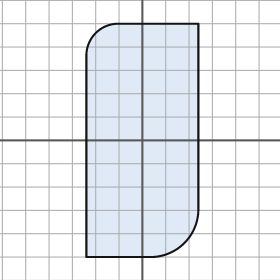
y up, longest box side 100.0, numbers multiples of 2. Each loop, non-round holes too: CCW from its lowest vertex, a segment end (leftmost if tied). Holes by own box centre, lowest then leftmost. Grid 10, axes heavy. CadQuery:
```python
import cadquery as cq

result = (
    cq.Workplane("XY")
    .moveTo(-24.0, -50.0)
    .lineTo(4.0, -50.0)
    .threePointArc((18.0, -44.0), (24.0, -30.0))
    .lineTo(24.0, 50.0)
    .lineTo(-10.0, 50.0)
    .threePointArc((-20.0, 46.0), (-24.0, 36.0))
    .close()
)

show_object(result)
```